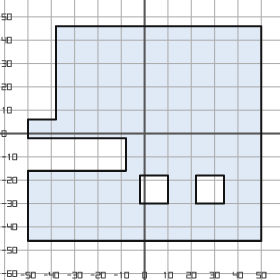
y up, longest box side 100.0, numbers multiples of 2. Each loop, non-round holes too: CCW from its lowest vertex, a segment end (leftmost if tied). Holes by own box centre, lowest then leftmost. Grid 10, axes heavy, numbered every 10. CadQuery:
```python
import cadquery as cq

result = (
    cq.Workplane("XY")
    .moveTo(-50.0, -46.0)
    .lineTo(50.0, -46.0)
    .lineTo(50.0, 46.0)
    .lineTo(-38.0, 46.0)
    .lineTo(-38.0, 6.0)
    .lineTo(-50.0, 6.0)
    .lineTo(-50.0, -2.0)
    .lineTo(-8.0, -2.0)
    .lineTo(-8.0, -16.0)
    .lineTo(-50.0, -16.0)
    .close()
    .moveTo(-2.0, -30.0)
    .lineTo(10.0, -30.0)
    .lineTo(10.0, -18.0)
    .lineTo(-2.0, -18.0)
    .close()
    .moveTo(22.0, -30.0)
    .lineTo(34.0, -30.0)
    .lineTo(34.0, -18.0)
    .lineTo(22.0, -18.0)
    .close()
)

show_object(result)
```